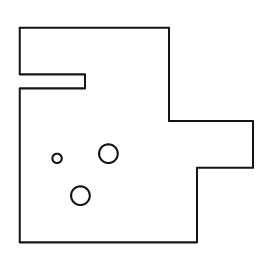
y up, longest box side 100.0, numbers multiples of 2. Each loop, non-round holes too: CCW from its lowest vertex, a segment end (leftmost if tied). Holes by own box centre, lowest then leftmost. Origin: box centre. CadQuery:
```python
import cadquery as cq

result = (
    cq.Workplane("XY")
    .moveTo(-50.0, -46.0)
    .lineTo(26.0, -46.0)
    .lineTo(26.0, -14.0)
    .lineTo(50.0, -14.0)
    .lineTo(50.0, 6.0)
    .lineTo(14.0, 6.0)
    .lineTo(14.0, 46.0)
    .lineTo(-50.0, 46.0)
    .lineTo(-50.0, 26.0)
    .lineTo(-22.0, 26.0)
    .lineTo(-22.0, 20.0)
    .lineTo(-50.0, 20.0)
    .close()
    .moveTo(-24.0, -26.0)
    .circle(4.0)
    .moveTo(-34.0, -10.0)
    .circle(2.0)
    .moveTo(-12.0, -8.0)
    .circle(4.0)
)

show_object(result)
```